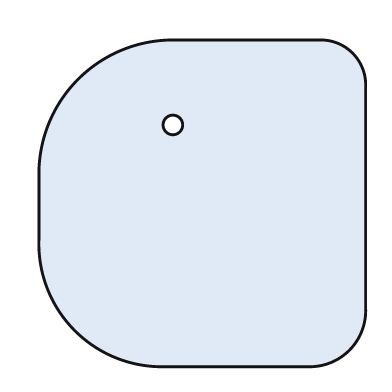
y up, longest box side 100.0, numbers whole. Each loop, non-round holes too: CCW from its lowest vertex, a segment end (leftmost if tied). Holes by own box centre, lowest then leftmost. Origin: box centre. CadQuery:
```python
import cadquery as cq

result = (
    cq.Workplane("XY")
    .moveTo(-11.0, -50.0)
    .lineTo(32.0, -50.0)
    .threePointArc((45.0, -45.0), (50.0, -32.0))
    .lineTo(50.0, 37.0)
    .threePointArc((46.0, 46.0), (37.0, 50.0))
    .lineTo(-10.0, 50.0)
    .threePointArc((-38.0, 38.0), (-50.0, 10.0))
    .lineTo(-50.0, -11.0)
    .threePointArc((-39.0, -39.0), (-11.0, -50.0))
    .close()
    .moveTo(-9.0, 24.0)
    .circle(3.0)
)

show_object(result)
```